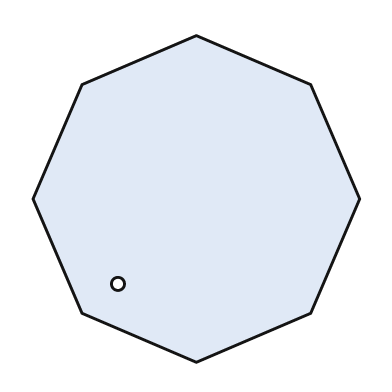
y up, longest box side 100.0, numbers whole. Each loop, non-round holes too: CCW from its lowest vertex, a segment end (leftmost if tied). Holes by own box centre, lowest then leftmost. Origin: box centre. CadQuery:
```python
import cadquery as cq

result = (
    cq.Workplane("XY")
    .moveTo(0.0, -50.0)
    .lineTo(35.0, -35.0)
    .lineTo(50.0, 0.0)
    .lineTo(35.0, 35.0)
    .lineTo(0.0, 50.0)
    .lineTo(-35.0, 35.0)
    .lineTo(-50.0, 0.0)
    .lineTo(-35.0, -35.0)
    .close()
    .moveTo(-24.0, -26.0)
    .circle(2.0)
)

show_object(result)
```